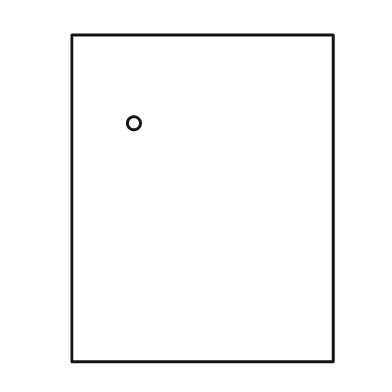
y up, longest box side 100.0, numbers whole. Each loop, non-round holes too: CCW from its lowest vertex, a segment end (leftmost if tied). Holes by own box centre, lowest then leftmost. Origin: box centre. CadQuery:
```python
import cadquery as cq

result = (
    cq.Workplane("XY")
    .moveTo(-40.0, -50.0)
    .lineTo(40.0, -50.0)
    .lineTo(40.0, 50.0)
    .lineTo(-40.0, 50.0)
    .close()
    .moveTo(-21.0, 23.0)
    .circle(2.0)
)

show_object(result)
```